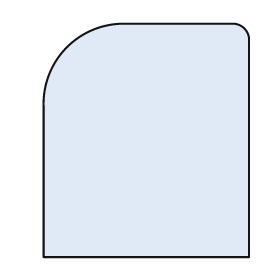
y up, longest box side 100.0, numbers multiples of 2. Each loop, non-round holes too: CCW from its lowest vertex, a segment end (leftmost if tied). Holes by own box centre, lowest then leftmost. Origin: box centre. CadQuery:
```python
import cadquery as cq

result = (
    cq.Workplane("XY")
    .moveTo(-44.0, -50.0)
    .lineTo(44.0, -50.0)
    .lineTo(44.0, 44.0)
    .threePointArc((42.0, 48.0), (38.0, 50.0))
    .lineTo(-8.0, 50.0)
    .threePointArc((-34.0, 40.0), (-44.0, 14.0))
    .close()
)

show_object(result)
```